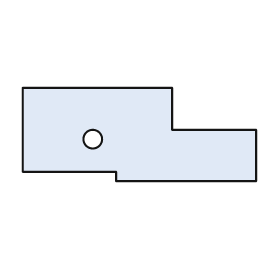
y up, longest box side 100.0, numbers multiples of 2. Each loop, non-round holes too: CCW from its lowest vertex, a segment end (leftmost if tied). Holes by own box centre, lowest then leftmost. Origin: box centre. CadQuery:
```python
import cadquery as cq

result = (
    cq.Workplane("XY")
    .moveTo(-10.0, -20.0)
    .lineTo(50.0, -20.0)
    .lineTo(50.0, 2.0)
    .lineTo(14.0, 2.0)
    .lineTo(14.0, 20.0)
    .lineTo(-50.0, 20.0)
    .lineTo(-50.0, -16.0)
    .lineTo(-10.0, -16.0)
    .close()
    .moveTo(-20.0, -2.0)
    .circle(4.0)
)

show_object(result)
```